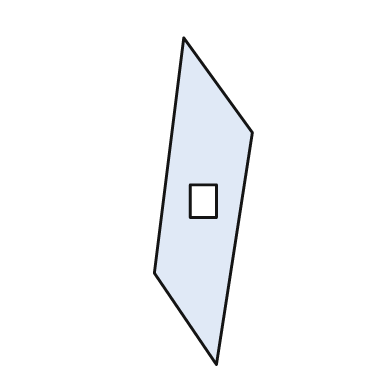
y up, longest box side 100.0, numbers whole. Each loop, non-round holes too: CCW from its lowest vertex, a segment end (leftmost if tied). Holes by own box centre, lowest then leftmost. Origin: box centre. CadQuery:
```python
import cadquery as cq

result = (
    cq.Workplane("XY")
    .moveTo(4.0, -50.0)
    .lineTo(15.0, 21.0)
    .lineTo(-6.0, 50.0)
    .lineTo(-15.0, -22.0)
    .close()
    .moveTo(-4.0, -5.0)
    .lineTo(4.0, -5.0)
    .lineTo(4.0, 5.0)
    .lineTo(-4.0, 5.0)
    .close()
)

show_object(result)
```